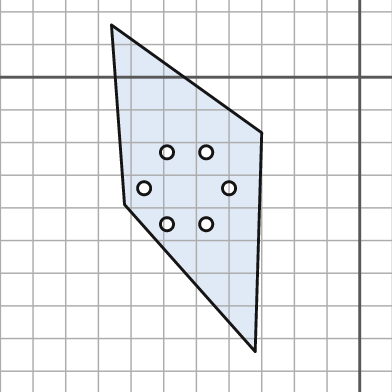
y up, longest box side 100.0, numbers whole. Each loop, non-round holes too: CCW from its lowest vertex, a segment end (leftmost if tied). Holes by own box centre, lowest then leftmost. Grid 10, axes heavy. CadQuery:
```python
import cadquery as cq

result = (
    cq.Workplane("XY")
    .moveTo(-32.0, -84.0)
    .lineTo(-30.0, -17.0)
    .lineTo(-76.0, 16.0)
    .lineTo(-72.0, -39.0)
    .close()
    .moveTo(-59.0, -45.0)
    .circle(2.0)
    .moveTo(-47.0, -45.0)
    .circle(2.0)
    .moveTo(-66.0, -34.0)
    .circle(2.0)
    .moveTo(-40.0, -34.0)
    .circle(2.0)
    .moveTo(-59.0, -23.0)
    .circle(2.0)
    .moveTo(-47.0, -23.0)
    .circle(2.0)
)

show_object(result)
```